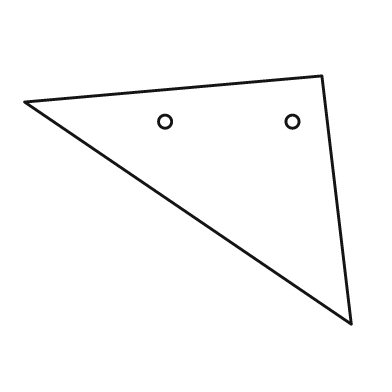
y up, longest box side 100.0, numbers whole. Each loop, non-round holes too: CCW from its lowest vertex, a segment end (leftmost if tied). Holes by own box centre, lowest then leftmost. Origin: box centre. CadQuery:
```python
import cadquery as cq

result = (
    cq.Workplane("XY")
    .moveTo(50.0, -38.0)
    .lineTo(41.0, 38.0)
    .lineTo(-50.0, 30.0)
    .close()
    .moveTo(-7.0, 24.0)
    .circle(2.0)
    .moveTo(32.0, 24.0)
    .circle(2.0)
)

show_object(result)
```